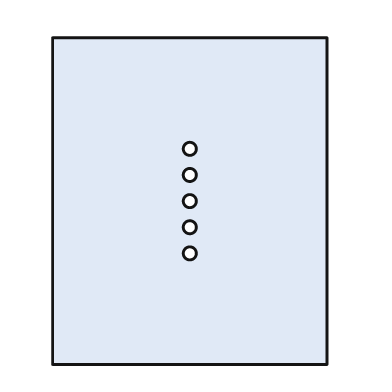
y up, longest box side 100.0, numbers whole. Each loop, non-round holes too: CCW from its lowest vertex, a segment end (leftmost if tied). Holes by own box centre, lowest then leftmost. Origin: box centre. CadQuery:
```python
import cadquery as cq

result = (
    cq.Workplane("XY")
    .moveTo(-42.0, -50.0)
    .lineTo(42.0, -50.0)
    .lineTo(42.0, 50.0)
    .lineTo(-42.0, 50.0)
    .close()
    .moveTo(0.0, -16.0)
    .circle(2.0)
    .moveTo(0.0, -8.0)
    .circle(2.0)
    .moveTo(0.0, 0.0)
    .circle(2.0)
    .moveTo(0.0, 8.0)
    .circle(2.0)
    .moveTo(0.0, 16.0)
    .circle(2.0)
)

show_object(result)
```